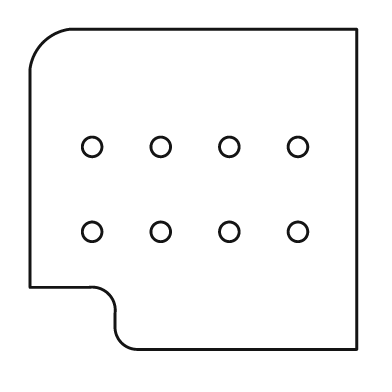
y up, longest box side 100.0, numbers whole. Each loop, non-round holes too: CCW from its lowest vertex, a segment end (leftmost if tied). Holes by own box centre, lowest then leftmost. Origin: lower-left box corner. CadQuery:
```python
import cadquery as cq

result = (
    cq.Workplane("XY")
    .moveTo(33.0, 0.0)
    .lineTo(100.0, 0.0)
    .lineTo(100.0, 98.0)
    .lineTo(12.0, 98.0)
    .threePointArc((4.0, 94.0), (0.0, 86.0))
    .lineTo(0.0, 19.0)
    .lineTo(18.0, 19.0)
    .threePointArc((24.0, 17.0), (26.0, 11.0))
    .lineTo(26.0, 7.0)
    .threePointArc((28.0, 2.0), (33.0, 0.0))
    .close()
    .moveTo(19.0, 36.0)
    .circle(3.0)
    .moveTo(40.0, 36.0)
    .circle(3.0)
    .moveTo(61.0, 36.0)
    .circle(3.0)
    .moveTo(82.0, 36.0)
    .circle(3.0)
    .moveTo(19.0, 62.0)
    .circle(3.0)
    .moveTo(40.0, 62.0)
    .circle(3.0)
    .moveTo(61.0, 62.0)
    .circle(3.0)
    .moveTo(82.0, 62.0)
    .circle(3.0)
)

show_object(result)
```